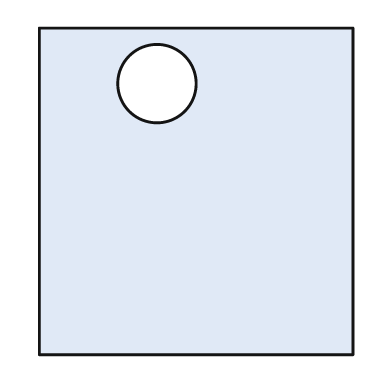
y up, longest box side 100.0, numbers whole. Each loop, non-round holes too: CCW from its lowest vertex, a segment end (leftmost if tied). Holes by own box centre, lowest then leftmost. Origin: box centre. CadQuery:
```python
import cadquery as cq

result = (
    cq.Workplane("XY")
    .moveTo(-48.0, -50.0)
    .lineTo(48.0, -50.0)
    .lineTo(48.0, 50.0)
    .lineTo(-48.0, 50.0)
    .close()
    .moveTo(-12.0, 33.0)
    .circle(12.0)
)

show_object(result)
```